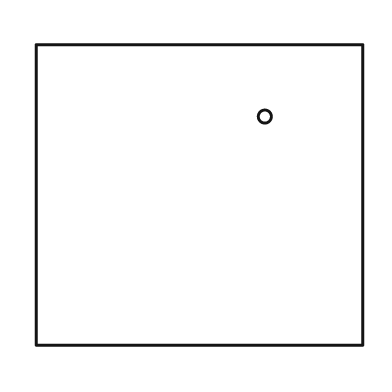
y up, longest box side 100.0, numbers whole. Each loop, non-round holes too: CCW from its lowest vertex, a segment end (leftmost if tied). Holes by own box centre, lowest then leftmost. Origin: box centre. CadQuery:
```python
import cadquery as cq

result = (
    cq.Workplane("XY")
    .moveTo(-50.0, -46.0)
    .lineTo(50.0, -46.0)
    .lineTo(50.0, 46.0)
    .lineTo(-50.0, 46.0)
    .close()
    .moveTo(20.0, 24.0)
    .circle(2.0)
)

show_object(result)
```